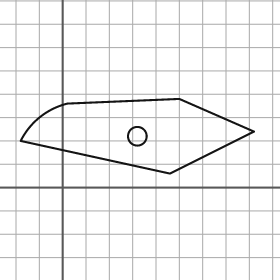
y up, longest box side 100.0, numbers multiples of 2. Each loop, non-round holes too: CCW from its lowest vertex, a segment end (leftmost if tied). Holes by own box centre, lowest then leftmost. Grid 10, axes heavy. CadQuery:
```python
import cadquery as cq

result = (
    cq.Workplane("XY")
    .moveTo(46.0, 6.0)
    .lineTo(82.0, 24.0)
    .lineTo(50.0, 38.0)
    .lineTo(2.0, 36.0)
    .threePointArc((-10.0, 30.0), (-18.0, 20.0))
    .close()
    .moveTo(32.0, 22.0)
    .circle(4.0)
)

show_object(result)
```